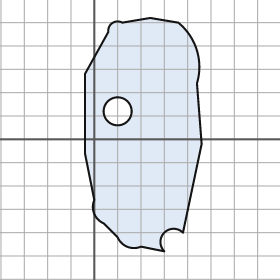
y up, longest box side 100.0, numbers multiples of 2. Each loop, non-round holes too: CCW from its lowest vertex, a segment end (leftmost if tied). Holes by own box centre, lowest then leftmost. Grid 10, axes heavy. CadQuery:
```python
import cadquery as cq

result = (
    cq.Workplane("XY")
    .moveTo(30.0, -48.0)
    .threePointArc((30.0, -40.0), (38.0, -40.0))
    .lineTo(46.0, -2.0)
    .lineTo(44.0, 24.0)
    .threePointArc((44.0, 38.0), (36.0, 50.0))
    .lineTo(24.0, 52.0)
    .lineTo(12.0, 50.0)
    .threePointArc((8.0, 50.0), (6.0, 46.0))
    .lineTo(-4.0, 28.0)
    .lineTo(-4.0, -6.0)
    .lineTo(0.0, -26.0)
    .threePointArc((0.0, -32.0), (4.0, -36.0))
    .lineTo(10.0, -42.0)
    .threePointArc((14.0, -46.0), (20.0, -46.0))
    .close()
    .moveTo(10.0, 12.0)
    .circle(6.0)
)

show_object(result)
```